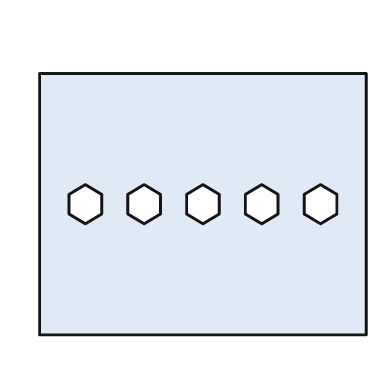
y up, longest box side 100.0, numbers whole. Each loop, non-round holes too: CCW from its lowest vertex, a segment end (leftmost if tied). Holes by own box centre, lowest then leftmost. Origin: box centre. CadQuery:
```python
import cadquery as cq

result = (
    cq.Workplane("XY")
    .moveTo(-50.0, -40.0)
    .lineTo(50.0, -40.0)
    .lineTo(50.0, 40.0)
    .lineTo(-50.0, 40.0)
    .close()
    .moveTo(-36.0, -6.0)
    .lineTo(-31.0, -3.0)
    .lineTo(-31.0, 3.0)
    .lineTo(-36.0, 6.0)
    .lineTo(-41.0, 3.0)
    .lineTo(-41.0, -3.0)
    .close()
    .moveTo(-18.0, -6.0)
    .lineTo(-13.0, -3.0)
    .lineTo(-13.0, 3.0)
    .lineTo(-18.0, 6.0)
    .lineTo(-23.0, 3.0)
    .lineTo(-23.0, -3.0)
    .close()
    .moveTo(0.0, -6.0)
    .lineTo(5.0, -3.0)
    .lineTo(5.0, 3.0)
    .lineTo(0.0, 6.0)
    .lineTo(-5.0, 3.0)
    .lineTo(-5.0, -3.0)
    .close()
    .moveTo(18.0, -6.0)
    .lineTo(23.0, -3.0)
    .lineTo(23.0, 3.0)
    .lineTo(18.0, 6.0)
    .lineTo(13.0, 3.0)
    .lineTo(13.0, -3.0)
    .close()
    .moveTo(36.0, -6.0)
    .lineTo(41.0, -3.0)
    .lineTo(41.0, 3.0)
    .lineTo(36.0, 6.0)
    .lineTo(31.0, 3.0)
    .lineTo(31.0, -3.0)
    .close()
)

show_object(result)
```